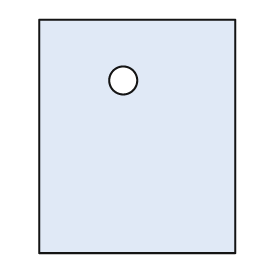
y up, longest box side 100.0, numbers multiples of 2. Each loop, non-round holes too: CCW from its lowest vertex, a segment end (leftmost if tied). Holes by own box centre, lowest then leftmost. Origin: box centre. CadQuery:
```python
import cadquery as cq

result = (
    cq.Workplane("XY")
    .moveTo(-42.0, -50.0)
    .lineTo(42.0, -50.0)
    .lineTo(42.0, 50.0)
    .lineTo(-42.0, 50.0)
    .close()
    .moveTo(-6.0, 24.0)
    .circle(6.0)
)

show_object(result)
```